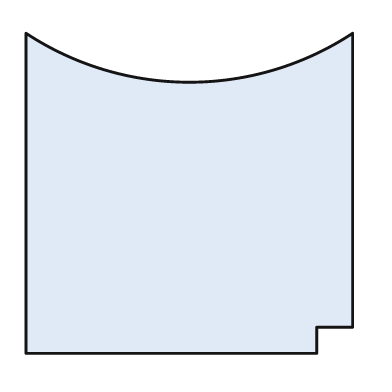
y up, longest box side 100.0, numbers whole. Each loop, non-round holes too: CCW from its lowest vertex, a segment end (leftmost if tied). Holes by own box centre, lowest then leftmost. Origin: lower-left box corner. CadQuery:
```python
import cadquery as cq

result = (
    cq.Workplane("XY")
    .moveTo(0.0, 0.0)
    .lineTo(89.0, 0.0)
    .lineTo(89.0, 8.0)
    .lineTo(100.0, 8.0)
    .lineTo(100.0, 98.0)
    .threePointArc((50.0, 83.0), (0.0, 98.0))
    .close()
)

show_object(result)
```